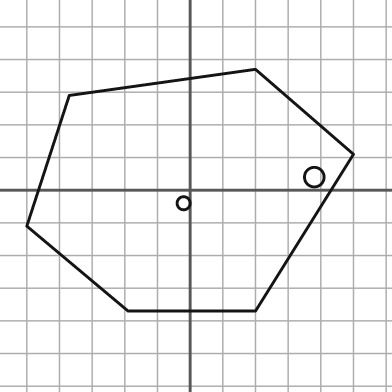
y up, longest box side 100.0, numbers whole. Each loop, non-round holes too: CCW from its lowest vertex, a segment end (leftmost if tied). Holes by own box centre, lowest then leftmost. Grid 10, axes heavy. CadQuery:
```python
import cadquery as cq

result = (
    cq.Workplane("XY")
    .moveTo(-19.0, -37.0)
    .lineTo(20.0, -37.0)
    .lineTo(50.0, 11.0)
    .lineTo(20.0, 37.0)
    .lineTo(-37.0, 29.0)
    .lineTo(-50.0, -11.0)
    .close()
    .moveTo(-2.0, -4.0)
    .circle(2.0)
    .moveTo(38.0, 4.0)
    .circle(3.0)
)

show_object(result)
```